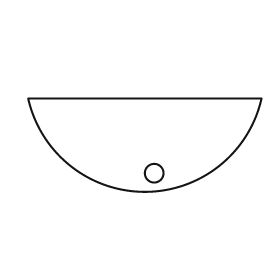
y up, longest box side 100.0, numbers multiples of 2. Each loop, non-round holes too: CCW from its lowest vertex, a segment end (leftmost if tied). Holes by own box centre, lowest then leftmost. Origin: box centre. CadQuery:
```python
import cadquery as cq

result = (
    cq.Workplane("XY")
    .moveTo(-50.0, 20.0)
    .threePointArc((0.0, -20.0), (50.0, 20.0))
    .close()
    .moveTo(4.0, -12.0)
    .circle(4.0)
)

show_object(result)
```